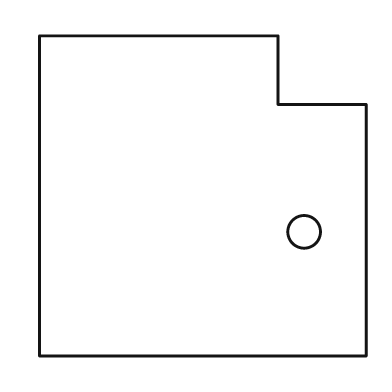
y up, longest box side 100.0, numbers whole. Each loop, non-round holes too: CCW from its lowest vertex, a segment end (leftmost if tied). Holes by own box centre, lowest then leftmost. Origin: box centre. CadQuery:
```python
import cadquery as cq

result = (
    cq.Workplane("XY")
    .moveTo(-50.0, -49.0)
    .lineTo(50.0, -49.0)
    .lineTo(50.0, 28.0)
    .lineTo(23.0, 28.0)
    .lineTo(23.0, 49.0)
    .lineTo(-50.0, 49.0)
    .close()
    .moveTo(31.0, -11.0)
    .circle(5.0)
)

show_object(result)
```